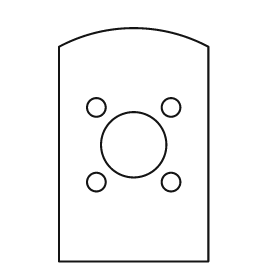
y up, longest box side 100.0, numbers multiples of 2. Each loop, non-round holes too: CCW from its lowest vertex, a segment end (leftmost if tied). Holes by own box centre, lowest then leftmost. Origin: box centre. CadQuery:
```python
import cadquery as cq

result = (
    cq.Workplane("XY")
    .moveTo(-32.0, -50.0)
    .lineTo(32.0, -50.0)
    .lineTo(32.0, 42.0)
    .threePointArc((0.0, 50.0), (-32.0, 42.0))
    .close()
    .moveTo(-16.0, -16.0)
    .circle(4.0)
    .moveTo(16.0, -16.0)
    .circle(4.0)
    .moveTo(0.0, 0.0)
    .circle(14.0)
    .moveTo(-16.0, 16.0)
    .circle(4.0)
    .moveTo(16.0, 16.0)
    .circle(4.0)
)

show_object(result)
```